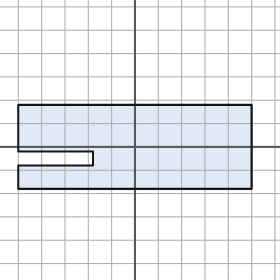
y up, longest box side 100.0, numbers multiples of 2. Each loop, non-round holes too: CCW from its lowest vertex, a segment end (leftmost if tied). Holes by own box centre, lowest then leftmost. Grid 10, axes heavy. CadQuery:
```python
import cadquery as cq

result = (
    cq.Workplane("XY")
    .moveTo(-50.0, -18.0)
    .lineTo(50.0, -18.0)
    .lineTo(50.0, 18.0)
    .lineTo(-50.0, 18.0)
    .lineTo(-50.0, -2.0)
    .lineTo(-18.0, -2.0)
    .lineTo(-18.0, -8.0)
    .lineTo(-50.0, -8.0)
    .close()
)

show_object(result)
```